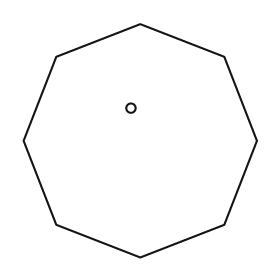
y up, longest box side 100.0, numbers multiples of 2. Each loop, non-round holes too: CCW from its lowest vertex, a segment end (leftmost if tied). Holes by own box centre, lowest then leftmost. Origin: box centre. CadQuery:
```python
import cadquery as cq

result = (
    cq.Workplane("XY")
    .moveTo(0.0, -50.0)
    .lineTo(36.0, -36.0)
    .lineTo(50.0, 0.0)
    .lineTo(36.0, 36.0)
    .lineTo(0.0, 50.0)
    .lineTo(-36.0, 36.0)
    .lineTo(-50.0, 0.0)
    .lineTo(-36.0, -36.0)
    .close()
    .moveTo(-4.0, 14.0)
    .circle(2.0)
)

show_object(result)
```